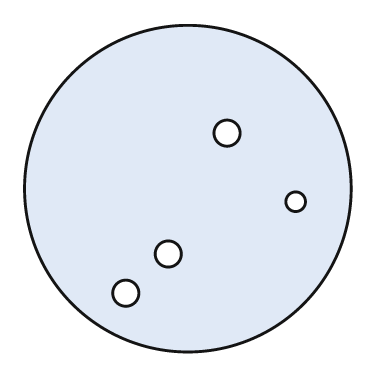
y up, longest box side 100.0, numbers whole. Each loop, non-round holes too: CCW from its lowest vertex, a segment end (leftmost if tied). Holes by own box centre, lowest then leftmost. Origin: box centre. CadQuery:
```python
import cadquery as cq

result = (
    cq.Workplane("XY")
    .moveTo(0.0, 0.0)
    .circle(50.0)
    .moveTo(-19.0, -32.0)
    .circle(4.0)
    .moveTo(-6.0, -20.0)
    .circle(4.0)
    .moveTo(33.0, -4.0)
    .circle(3.0)
    .moveTo(12.0, 17.0)
    .circle(4.0)
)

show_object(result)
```